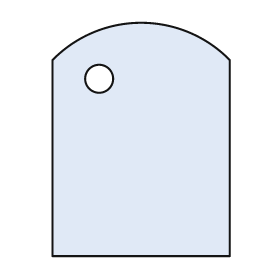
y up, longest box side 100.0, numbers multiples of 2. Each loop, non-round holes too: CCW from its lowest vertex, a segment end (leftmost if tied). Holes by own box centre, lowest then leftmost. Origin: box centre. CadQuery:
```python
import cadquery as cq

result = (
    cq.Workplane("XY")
    .moveTo(-38.0, -50.0)
    .lineTo(38.0, -50.0)
    .lineTo(38.0, 34.0)
    .threePointArc((0.0, 50.0), (-38.0, 34.0))
    .close()
    .moveTo(-18.0, 26.0)
    .circle(6.0)
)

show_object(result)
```